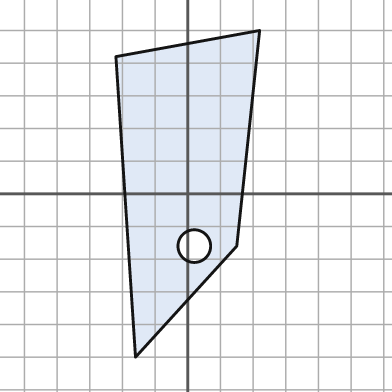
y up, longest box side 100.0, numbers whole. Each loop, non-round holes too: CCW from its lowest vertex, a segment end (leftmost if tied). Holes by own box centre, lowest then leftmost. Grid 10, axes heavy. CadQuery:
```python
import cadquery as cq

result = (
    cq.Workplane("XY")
    .moveTo(-16.0, -50.0)
    .lineTo(15.0, -16.0)
    .lineTo(22.0, 50.0)
    .lineTo(-22.0, 42.0)
    .close()
    .moveTo(2.0, -16.0)
    .circle(5.0)
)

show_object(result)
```